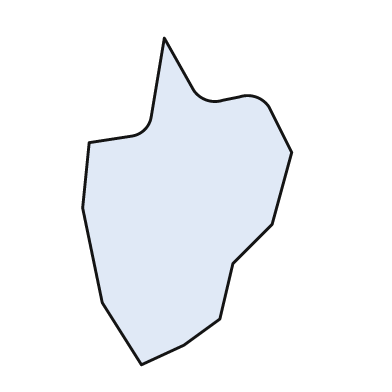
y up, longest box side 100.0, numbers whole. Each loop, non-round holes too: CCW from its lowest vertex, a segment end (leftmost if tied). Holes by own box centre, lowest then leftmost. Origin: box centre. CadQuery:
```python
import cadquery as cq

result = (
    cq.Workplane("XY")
    .moveTo(-14.0, -50.0)
    .lineTo(-1.0, -44.0)
    .lineTo(10.0, -36.0)
    .lineTo(14.0, -19.0)
    .lineTo(26.0, -7.0)
    .lineTo(32.0, 15.0)
    .lineTo(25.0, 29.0)
    .threePointArc((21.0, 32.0), (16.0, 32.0))
    .lineTo(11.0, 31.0)
    .threePointArc((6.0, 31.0), (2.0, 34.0))
    .lineTo(-7.0, 50.0)
    .lineTo(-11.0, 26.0)
    .threePointArc((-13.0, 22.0), (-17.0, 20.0))
    .lineTo(-30.0, 18.0)
    .lineTo(-32.0, -2.0)
    .lineTo(-26.0, -31.0)
    .close()
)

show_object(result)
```